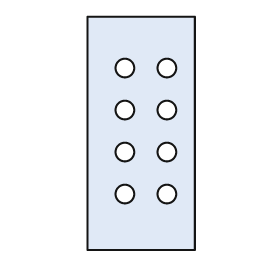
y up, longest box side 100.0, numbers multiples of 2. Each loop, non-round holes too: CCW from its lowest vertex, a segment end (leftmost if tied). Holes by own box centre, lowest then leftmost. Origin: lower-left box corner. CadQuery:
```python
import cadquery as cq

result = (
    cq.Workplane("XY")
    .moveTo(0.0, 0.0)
    .lineTo(46.0, 0.0)
    .lineTo(46.0, 100.0)
    .lineTo(0.0, 100.0)
    .close()
    .moveTo(16.0, 24.0)
    .circle(4.0)
    .moveTo(34.0, 24.0)
    .circle(4.0)
    .moveTo(16.0, 42.0)
    .circle(4.0)
    .moveTo(34.0, 42.0)
    .circle(4.0)
    .moveTo(16.0, 60.0)
    .circle(4.0)
    .moveTo(34.0, 60.0)
    .circle(4.0)
    .moveTo(16.0, 78.0)
    .circle(4.0)
    .moveTo(34.0, 78.0)
    .circle(4.0)
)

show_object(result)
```